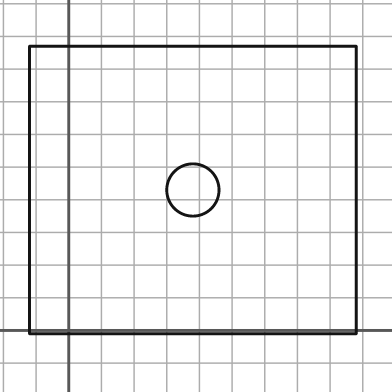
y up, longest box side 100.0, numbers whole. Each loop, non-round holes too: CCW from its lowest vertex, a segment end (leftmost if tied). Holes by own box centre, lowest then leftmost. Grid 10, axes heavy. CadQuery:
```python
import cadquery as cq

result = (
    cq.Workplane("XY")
    .moveTo(-12.0, -1.0)
    .lineTo(88.0, -1.0)
    .lineTo(88.0, 87.0)
    .lineTo(-12.0, 87.0)
    .close()
    .moveTo(38.0, 43.0)
    .circle(8.0)
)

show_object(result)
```